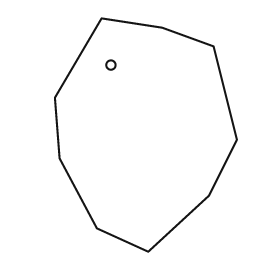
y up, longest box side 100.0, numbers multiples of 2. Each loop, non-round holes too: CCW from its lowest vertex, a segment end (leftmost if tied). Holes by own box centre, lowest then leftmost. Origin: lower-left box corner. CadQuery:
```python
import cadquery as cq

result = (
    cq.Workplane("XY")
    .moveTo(40.0, 0.0)
    .lineTo(66.0, 24.0)
    .lineTo(78.0, 48.0)
    .lineTo(68.0, 88.0)
    .lineTo(46.0, 96.0)
    .lineTo(20.0, 100.0)
    .lineTo(0.0, 66.0)
    .lineTo(2.0, 40.0)
    .lineTo(18.0, 10.0)
    .close()
    .moveTo(24.0, 80.0)
    .circle(2.0)
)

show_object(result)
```